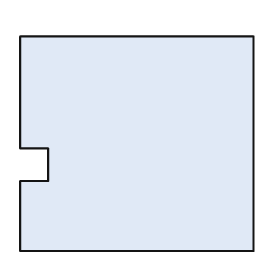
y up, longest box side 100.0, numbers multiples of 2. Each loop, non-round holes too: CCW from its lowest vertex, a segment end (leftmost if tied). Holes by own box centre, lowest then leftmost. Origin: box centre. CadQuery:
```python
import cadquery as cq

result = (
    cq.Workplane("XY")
    .moveTo(-50.0, -46.0)
    .lineTo(50.0, -46.0)
    .lineTo(50.0, 46.0)
    .lineTo(-50.0, 46.0)
    .lineTo(-50.0, -2.0)
    .lineTo(-38.0, -2.0)
    .lineTo(-38.0, -16.0)
    .lineTo(-50.0, -16.0)
    .close()
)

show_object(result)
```